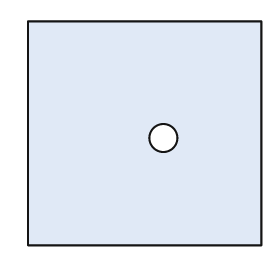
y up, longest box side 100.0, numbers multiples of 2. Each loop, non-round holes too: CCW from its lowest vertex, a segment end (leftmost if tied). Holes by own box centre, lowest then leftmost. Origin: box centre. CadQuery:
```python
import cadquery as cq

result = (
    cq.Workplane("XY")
    .moveTo(-50.0, -48.0)
    .lineTo(50.0, -48.0)
    .lineTo(50.0, 48.0)
    .lineTo(-50.0, 48.0)
    .close()
    .moveTo(8.0, -2.0)
    .circle(6.0)
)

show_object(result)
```